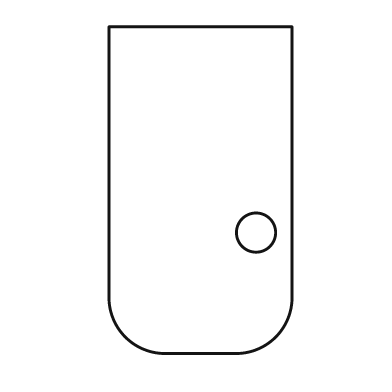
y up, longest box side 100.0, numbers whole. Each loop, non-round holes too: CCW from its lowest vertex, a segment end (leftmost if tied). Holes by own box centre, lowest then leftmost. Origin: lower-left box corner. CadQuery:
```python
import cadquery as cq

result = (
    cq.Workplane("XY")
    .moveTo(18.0, 0.0)
    .lineTo(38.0, 0.0)
    .threePointArc((51.0, 5.0), (56.0, 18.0))
    .lineTo(56.0, 100.0)
    .lineTo(0.0, 100.0)
    .lineTo(0.0, 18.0)
    .threePointArc((5.0, 5.0), (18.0, 0.0))
    .close()
    .moveTo(45.0, 37.0)
    .circle(6.0)
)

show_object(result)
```